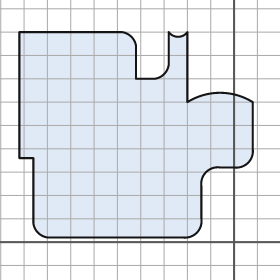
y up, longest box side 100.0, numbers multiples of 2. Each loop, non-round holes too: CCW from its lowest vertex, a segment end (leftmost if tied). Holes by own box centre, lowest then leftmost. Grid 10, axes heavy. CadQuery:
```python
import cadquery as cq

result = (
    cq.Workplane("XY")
    .moveTo(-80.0, 2.0)
    .lineTo(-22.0, 2.0)
    .threePointArc((-16.0, 4.0), (-14.0, 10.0))
    .lineTo(-14.0, 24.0)
    .threePointArc((-12.0, 30.0), (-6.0, 32.0))
    .lineTo(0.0, 32.0)
    .threePointArc((6.0, 34.0), (8.0, 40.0))
    .lineTo(8.0, 60.0)
    .threePointArc((-6.0, 64.0), (-20.0, 60.0))
    .lineTo(-20.0, 90.0)
    .threePointArc((-24.0, 88.0), (-28.0, 90.0))
    .lineTo(-28.0, 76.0)
    .threePointArc((-30.0, 72.0), (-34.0, 70.0))
    .lineTo(-42.0, 70.0)
    .lineTo(-42.0, 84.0)
    .threePointArc((-44.0, 88.0), (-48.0, 90.0))
    .lineTo(-92.0, 90.0)
    .lineTo(-92.0, 36.0)
    .lineTo(-86.0, 36.0)
    .lineTo(-86.0, 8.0)
    .threePointArc((-84.0, 4.0), (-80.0, 2.0))
    .close()
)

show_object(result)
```